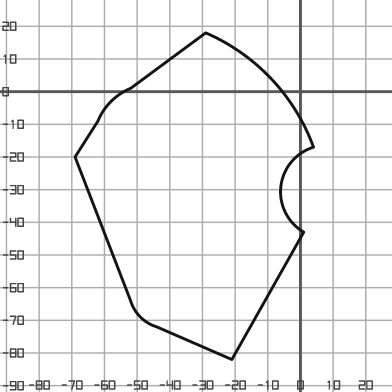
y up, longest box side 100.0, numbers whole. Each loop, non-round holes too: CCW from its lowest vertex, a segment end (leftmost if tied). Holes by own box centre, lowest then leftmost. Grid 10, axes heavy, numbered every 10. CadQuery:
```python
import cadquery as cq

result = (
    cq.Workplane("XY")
    .moveTo(-21.0, -82.0)
    .lineTo(1.0, -43.0)
    .threePointArc((-6.0, -29.0), (4.0, -17.0))
    .threePointArc((-9.0, 4.0), (-29.0, 18.0))
    .lineTo(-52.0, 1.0)
    .threePointArc((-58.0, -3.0), (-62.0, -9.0))
    .lineTo(-69.0, -20.0)
    .lineTo(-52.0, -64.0)
    .threePointArc((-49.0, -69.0), (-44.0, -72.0))
    .close()
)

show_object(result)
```